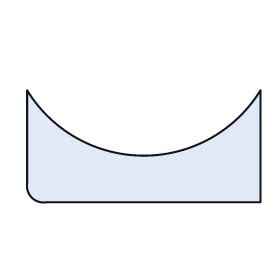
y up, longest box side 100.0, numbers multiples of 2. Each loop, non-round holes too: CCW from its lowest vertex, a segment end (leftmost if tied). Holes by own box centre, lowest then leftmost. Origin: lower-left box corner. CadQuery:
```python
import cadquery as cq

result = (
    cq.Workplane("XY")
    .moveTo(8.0, 0.0)
    .lineTo(100.0, 0.0)
    .lineTo(100.0, 48.0)
    .threePointArc((50.0, 20.0), (0.0, 48.0))
    .lineTo(0.0, 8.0)
    .threePointArc((2.0, 2.0), (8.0, 0.0))
    .close()
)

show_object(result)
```